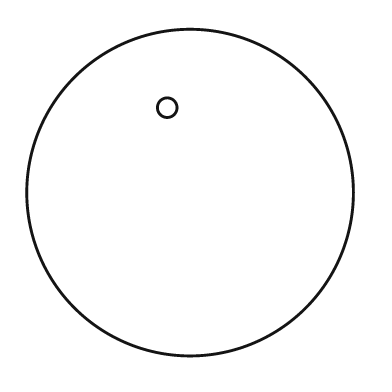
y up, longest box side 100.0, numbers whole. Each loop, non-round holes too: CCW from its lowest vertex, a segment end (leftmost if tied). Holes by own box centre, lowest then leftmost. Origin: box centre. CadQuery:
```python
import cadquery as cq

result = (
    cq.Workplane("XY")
    .moveTo(0.0, 0.0)
    .circle(50.0)
    .moveTo(-7.0, 26.0)
    .circle(3.0)
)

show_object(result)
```